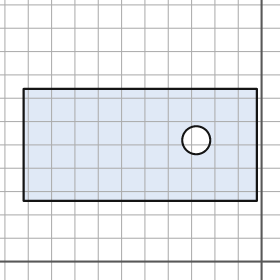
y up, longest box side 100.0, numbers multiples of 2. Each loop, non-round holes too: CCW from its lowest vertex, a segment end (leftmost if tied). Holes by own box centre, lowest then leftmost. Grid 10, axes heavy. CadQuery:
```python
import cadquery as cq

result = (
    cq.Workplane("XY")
    .moveTo(-102.0, 26.0)
    .lineTo(-2.0, 26.0)
    .lineTo(-2.0, 74.0)
    .lineTo(-102.0, 74.0)
    .close()
    .moveTo(-28.0, 52.0)
    .circle(6.0)
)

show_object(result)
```